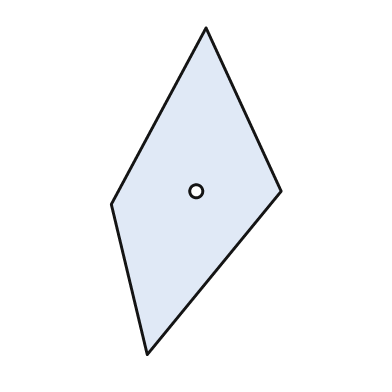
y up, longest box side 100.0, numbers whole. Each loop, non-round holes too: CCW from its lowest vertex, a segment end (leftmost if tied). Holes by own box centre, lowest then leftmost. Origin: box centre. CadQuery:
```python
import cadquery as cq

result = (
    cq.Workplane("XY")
    .moveTo(-15.0, -50.0)
    .lineTo(26.0, 0.0)
    .lineTo(3.0, 50.0)
    .lineTo(-26.0, -4.0)
    .close()
    .moveTo(0.0, 0.0)
    .circle(2.0)
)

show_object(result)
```